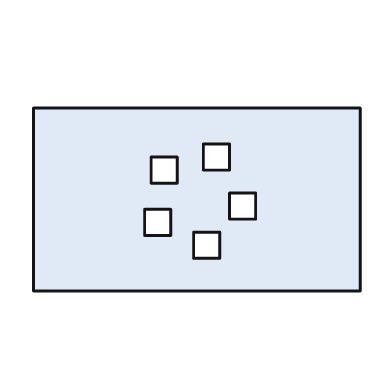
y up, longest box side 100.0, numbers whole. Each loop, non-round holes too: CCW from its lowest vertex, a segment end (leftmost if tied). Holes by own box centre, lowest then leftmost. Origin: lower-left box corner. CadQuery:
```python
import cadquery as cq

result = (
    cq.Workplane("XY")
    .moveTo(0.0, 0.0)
    .lineTo(100.0, 0.0)
    .lineTo(100.0, 56.0)
    .lineTo(0.0, 56.0)
    .close()
    .moveTo(49.0, 10.0)
    .lineTo(57.0, 10.0)
    .lineTo(57.0, 18.0)
    .lineTo(49.0, 18.0)
    .close()
    .moveTo(34.0, 17.0)
    .lineTo(42.0, 17.0)
    .lineTo(42.0, 25.0)
    .lineTo(34.0, 25.0)
    .close()
    .moveTo(60.0, 22.0)
    .lineTo(68.0, 22.0)
    .lineTo(68.0, 30.0)
    .lineTo(60.0, 30.0)
    .close()
    .moveTo(36.0, 33.0)
    .lineTo(44.0, 33.0)
    .lineTo(44.0, 41.0)
    .lineTo(36.0, 41.0)
    .close()
    .moveTo(52.0, 37.0)
    .lineTo(60.0, 37.0)
    .lineTo(60.0, 45.0)
    .lineTo(52.0, 45.0)
    .close()
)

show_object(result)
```